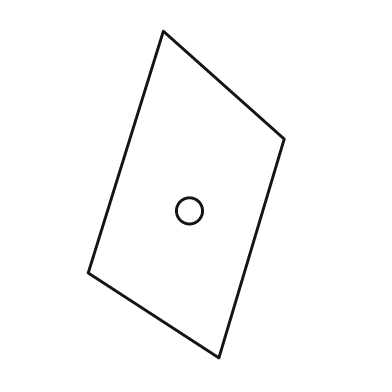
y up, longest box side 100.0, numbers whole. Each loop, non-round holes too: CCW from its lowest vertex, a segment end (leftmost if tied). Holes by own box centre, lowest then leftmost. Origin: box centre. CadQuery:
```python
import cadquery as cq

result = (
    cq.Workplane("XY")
    .moveTo(10.0, -50.0)
    .lineTo(30.0, 17.0)
    .lineTo(-7.0, 50.0)
    .lineTo(-30.0, -24.0)
    .close()
    .moveTo(1.0, -5.0)
    .circle(4.0)
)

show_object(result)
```